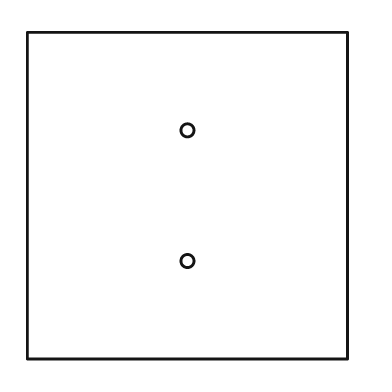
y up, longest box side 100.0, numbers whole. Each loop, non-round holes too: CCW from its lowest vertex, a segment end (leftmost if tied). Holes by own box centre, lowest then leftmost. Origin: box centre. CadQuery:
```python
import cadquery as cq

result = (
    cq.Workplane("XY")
    .moveTo(-49.0, -50.0)
    .lineTo(49.0, -50.0)
    .lineTo(49.0, 50.0)
    .lineTo(-49.0, 50.0)
    .close()
    .moveTo(0.0, -20.0)
    .circle(2.0)
    .moveTo(0.0, 20.0)
    .circle(2.0)
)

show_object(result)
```